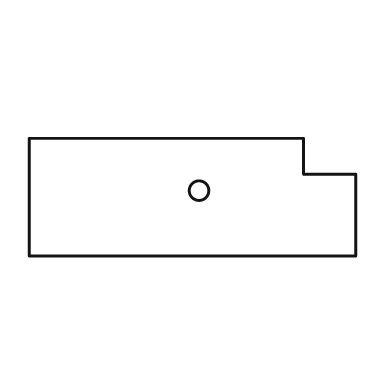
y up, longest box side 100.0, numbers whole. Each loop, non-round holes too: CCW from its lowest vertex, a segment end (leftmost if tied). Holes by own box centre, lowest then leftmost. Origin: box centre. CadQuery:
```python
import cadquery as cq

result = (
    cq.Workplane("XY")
    .moveTo(-50.0, -18.0)
    .lineTo(50.0, -18.0)
    .lineTo(50.0, 7.0)
    .lineTo(34.0, 7.0)
    .lineTo(34.0, 18.0)
    .lineTo(-50.0, 18.0)
    .close()
    .moveTo(2.0, 2.0)
    .circle(3.0)
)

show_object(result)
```